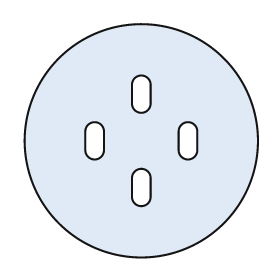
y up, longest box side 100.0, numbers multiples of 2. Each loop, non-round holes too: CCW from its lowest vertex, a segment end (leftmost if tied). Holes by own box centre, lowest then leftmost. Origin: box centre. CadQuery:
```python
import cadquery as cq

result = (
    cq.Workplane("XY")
    .moveTo(0.0, 0.0)
    .circle(50.0)
    .moveTo(-4.0, -24.0)
    .threePointArc((0.0, -28.0), (4.0, -24.0))
    .lineTo(4.0, -16.0)
    .threePointArc((0.0, -12.0), (-4.0, -16.0))
    .close()
    .moveTo(-24.0, -4.0)
    .threePointArc((-20.0, -8.0), (-16.0, -4.0))
    .lineTo(-16.0, 4.0)
    .threePointArc((-20.0, 8.0), (-24.0, 4.0))
    .close()
    .moveTo(16.0, -4.0)
    .threePointArc((20.0, -8.0), (24.0, -4.0))
    .lineTo(24.0, 4.0)
    .threePointArc((20.0, 8.0), (16.0, 4.0))
    .close()
    .moveTo(-4.0, 16.0)
    .threePointArc((0.0, 12.0), (4.0, 16.0))
    .lineTo(4.0, 24.0)
    .threePointArc((0.0, 28.0), (-4.0, 24.0))
    .close()
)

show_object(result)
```